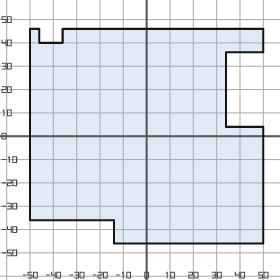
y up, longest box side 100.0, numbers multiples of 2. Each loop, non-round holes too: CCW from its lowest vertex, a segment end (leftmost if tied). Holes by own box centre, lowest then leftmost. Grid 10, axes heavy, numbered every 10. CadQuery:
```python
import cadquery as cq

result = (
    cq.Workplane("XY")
    .moveTo(-14.0, -46.0)
    .lineTo(50.0, -46.0)
    .lineTo(50.0, 4.0)
    .lineTo(34.0, 4.0)
    .lineTo(34.0, 36.0)
    .lineTo(50.0, 36.0)
    .lineTo(50.0, 46.0)
    .lineTo(-36.0, 46.0)
    .lineTo(-36.0, 40.0)
    .lineTo(-46.0, 40.0)
    .lineTo(-46.0, 46.0)
    .lineTo(-50.0, 46.0)
    .lineTo(-50.0, -36.0)
    .lineTo(-14.0, -36.0)
    .close()
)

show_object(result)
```